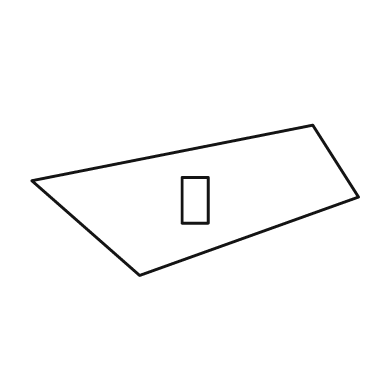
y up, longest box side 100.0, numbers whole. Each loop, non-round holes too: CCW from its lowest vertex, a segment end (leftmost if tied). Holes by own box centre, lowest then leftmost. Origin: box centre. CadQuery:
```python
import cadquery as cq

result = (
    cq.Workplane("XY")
    .moveTo(-17.0, -23.0)
    .lineTo(50.0, 1.0)
    .lineTo(36.0, 23.0)
    .lineTo(-50.0, 6.0)
    .close()
    .moveTo(-4.0, -7.0)
    .lineTo(4.0, -7.0)
    .lineTo(4.0, 7.0)
    .lineTo(-4.0, 7.0)
    .close()
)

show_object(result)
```